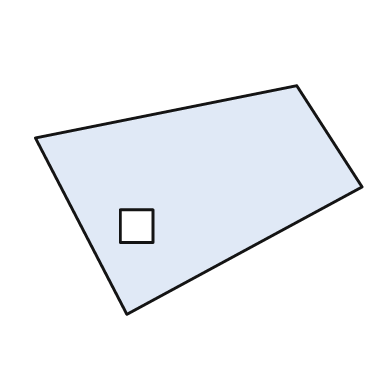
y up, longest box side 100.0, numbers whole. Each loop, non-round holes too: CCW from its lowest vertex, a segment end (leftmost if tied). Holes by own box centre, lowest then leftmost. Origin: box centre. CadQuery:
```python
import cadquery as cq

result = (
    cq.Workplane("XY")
    .moveTo(-22.0, -35.0)
    .lineTo(50.0, 4.0)
    .lineTo(30.0, 35.0)
    .lineTo(-50.0, 19.0)
    .close()
    .moveTo(-24.0, -13.0)
    .lineTo(-14.0, -13.0)
    .lineTo(-14.0, -3.0)
    .lineTo(-24.0, -3.0)
    .close()
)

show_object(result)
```